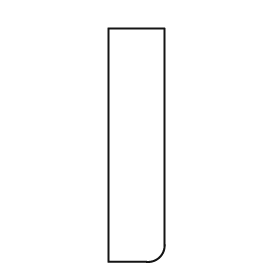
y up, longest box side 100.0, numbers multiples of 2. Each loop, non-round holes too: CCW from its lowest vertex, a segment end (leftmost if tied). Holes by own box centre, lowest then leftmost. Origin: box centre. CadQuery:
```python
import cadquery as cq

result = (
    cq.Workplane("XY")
    .moveTo(-12.0, -50.0)
    .lineTo(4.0, -50.0)
    .threePointArc((10.0, -48.0), (12.0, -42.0))
    .lineTo(12.0, 50.0)
    .lineTo(-12.0, 50.0)
    .close()
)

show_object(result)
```